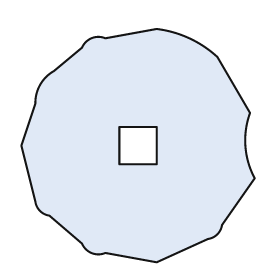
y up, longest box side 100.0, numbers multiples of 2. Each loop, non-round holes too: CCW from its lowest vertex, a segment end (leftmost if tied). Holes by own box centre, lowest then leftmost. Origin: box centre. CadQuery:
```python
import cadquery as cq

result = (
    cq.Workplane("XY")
    .moveTo(8.0, -50.0)
    .lineTo(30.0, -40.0)
    .threePointArc((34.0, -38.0), (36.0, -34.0))
    .lineTo(50.0, -14.0)
    .threePointArc((46.0, 0.0), (48.0, 14.0))
    .lineTo(34.0, 38.0)
    .threePointArc((22.0, 46.0), (8.0, 50.0))
    .lineTo(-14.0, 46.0)
    .threePointArc((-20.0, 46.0), (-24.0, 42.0))
    .lineTo(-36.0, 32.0)
    .threePointArc((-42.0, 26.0), (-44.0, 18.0))
    .lineTo(-50.0, 0.0)
    .lineTo(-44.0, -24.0)
    .threePointArc((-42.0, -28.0), (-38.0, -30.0))
    .lineTo(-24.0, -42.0)
    .threePointArc((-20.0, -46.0), (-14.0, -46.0))
    .close()
    .moveTo(-8.0, -8.0)
    .lineTo(8.0, -8.0)
    .lineTo(8.0, 8.0)
    .lineTo(-8.0, 8.0)
    .close()
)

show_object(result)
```